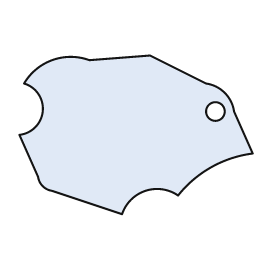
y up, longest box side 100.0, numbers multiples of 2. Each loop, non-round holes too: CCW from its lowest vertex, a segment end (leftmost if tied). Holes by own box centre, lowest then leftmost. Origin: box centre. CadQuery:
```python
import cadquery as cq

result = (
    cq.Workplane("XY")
    .moveTo(-6.0, -34.0)
    .threePointArc((4.0, -24.0), (18.0, -26.0))
    .threePointArc((32.0, -14.0), (50.0, -8.0))
    .lineTo(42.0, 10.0)
    .threePointArc((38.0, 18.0), (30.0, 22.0))
    .lineTo(6.0, 34.0)
    .lineTo(-20.0, 32.0)
    .threePointArc((-36.0, 32.0), (-48.0, 22.0))
    .threePointArc((-40.0, 10.0), (-50.0, 0.0))
    .lineTo(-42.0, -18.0)
    .threePointArc((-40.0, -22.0), (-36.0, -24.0))
    .close()
    .moveTo(34.0, 10.0)
    .circle(4.0)
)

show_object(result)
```